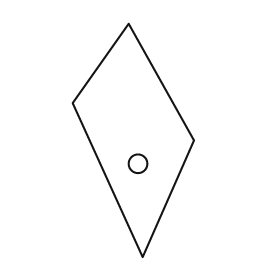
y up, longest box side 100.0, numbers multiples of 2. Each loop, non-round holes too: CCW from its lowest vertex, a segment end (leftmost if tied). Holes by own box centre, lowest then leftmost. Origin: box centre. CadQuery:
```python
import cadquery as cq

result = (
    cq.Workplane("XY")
    .moveTo(4.0, -50.0)
    .lineTo(26.0, 0.0)
    .lineTo(-2.0, 50.0)
    .lineTo(-26.0, 16.0)
    .close()
    .moveTo(2.0, -10.0)
    .circle(4.0)
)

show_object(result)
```